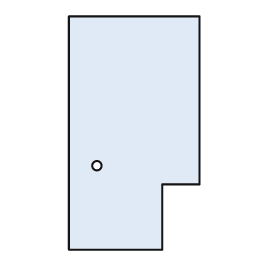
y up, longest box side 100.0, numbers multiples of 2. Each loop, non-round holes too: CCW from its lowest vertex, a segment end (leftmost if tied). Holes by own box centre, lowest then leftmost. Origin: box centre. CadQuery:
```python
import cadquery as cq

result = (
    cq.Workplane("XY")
    .moveTo(-28.0, -50.0)
    .lineTo(12.0, -50.0)
    .lineTo(12.0, -22.0)
    .lineTo(28.0, -22.0)
    .lineTo(28.0, 50.0)
    .lineTo(-28.0, 50.0)
    .close()
    .moveTo(-16.0, -14.0)
    .circle(2.0)
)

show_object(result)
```